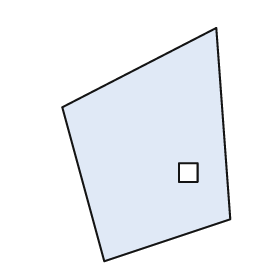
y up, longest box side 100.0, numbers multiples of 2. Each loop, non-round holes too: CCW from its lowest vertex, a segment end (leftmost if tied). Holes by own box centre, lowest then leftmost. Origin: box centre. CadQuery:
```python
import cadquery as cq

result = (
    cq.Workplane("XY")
    .moveTo(-18.0, -50.0)
    .lineTo(36.0, -32.0)
    .lineTo(30.0, 50.0)
    .lineTo(-36.0, 16.0)
    .close()
    .moveTo(14.0, -16.0)
    .lineTo(22.0, -16.0)
    .lineTo(22.0, -8.0)
    .lineTo(14.0, -8.0)
    .close()
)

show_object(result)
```